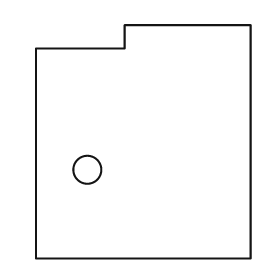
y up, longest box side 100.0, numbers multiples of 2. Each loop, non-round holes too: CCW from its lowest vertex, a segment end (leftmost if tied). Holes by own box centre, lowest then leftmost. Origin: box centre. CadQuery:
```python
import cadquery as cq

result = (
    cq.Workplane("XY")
    .moveTo(-46.0, -50.0)
    .lineTo(46.0, -50.0)
    .lineTo(46.0, 50.0)
    .lineTo(-8.0, 50.0)
    .lineTo(-8.0, 40.0)
    .lineTo(-46.0, 40.0)
    .close()
    .moveTo(-24.0, -12.0)
    .circle(6.0)
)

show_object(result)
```